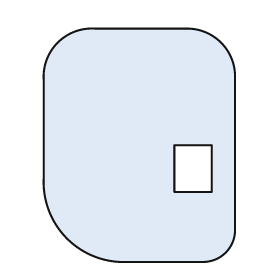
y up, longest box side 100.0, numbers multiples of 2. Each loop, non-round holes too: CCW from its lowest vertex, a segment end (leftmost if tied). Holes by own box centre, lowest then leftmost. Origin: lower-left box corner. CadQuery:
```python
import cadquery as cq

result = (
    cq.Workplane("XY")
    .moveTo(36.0, 0.0)
    .lineTo(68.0, 0.0)
    .threePointArc((78.0, 4.0), (82.0, 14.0))
    .lineTo(82.0, 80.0)
    .threePointArc((76.0, 94.0), (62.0, 100.0))
    .lineTo(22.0, 100.0)
    .threePointArc((6.0, 94.0), (0.0, 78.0))
    .lineTo(0.0, 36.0)
    .threePointArc((10.0, 10.0), (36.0, 0.0))
    .close()
    .moveTo(56.0, 30.0)
    .lineTo(72.0, 30.0)
    .lineTo(72.0, 50.0)
    .lineTo(56.0, 50.0)
    .close()
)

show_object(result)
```